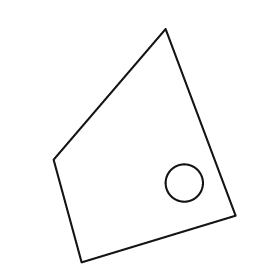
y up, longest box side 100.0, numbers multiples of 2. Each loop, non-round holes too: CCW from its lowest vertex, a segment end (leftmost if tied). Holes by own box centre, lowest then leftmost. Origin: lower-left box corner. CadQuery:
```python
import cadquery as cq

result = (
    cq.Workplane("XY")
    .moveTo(12.0, 0.0)
    .lineTo(78.0, 20.0)
    .lineTo(48.0, 100.0)
    .lineTo(0.0, 44.0)
    .close()
    .moveTo(56.0, 34.0)
    .circle(8.0)
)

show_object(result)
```